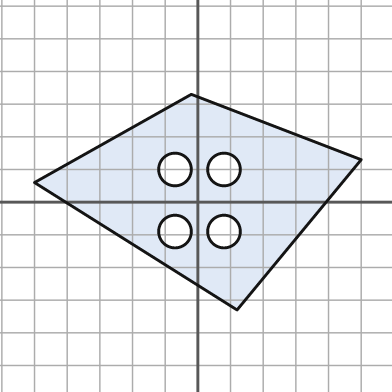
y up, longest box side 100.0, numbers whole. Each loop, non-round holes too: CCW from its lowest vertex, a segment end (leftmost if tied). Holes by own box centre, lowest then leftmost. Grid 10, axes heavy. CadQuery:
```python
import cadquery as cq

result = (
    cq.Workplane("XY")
    .moveTo(12.0, -33.0)
    .lineTo(50.0, 13.0)
    .lineTo(-2.0, 33.0)
    .lineTo(-50.0, 6.0)
    .close()
    .moveTo(-7.0, -9.0)
    .circle(5.0)
    .moveTo(8.0, -9.0)
    .circle(5.0)
    .moveTo(-7.0, 10.0)
    .circle(5.0)
    .moveTo(8.0, 10.0)
    .circle(5.0)
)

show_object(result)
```